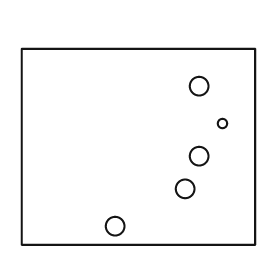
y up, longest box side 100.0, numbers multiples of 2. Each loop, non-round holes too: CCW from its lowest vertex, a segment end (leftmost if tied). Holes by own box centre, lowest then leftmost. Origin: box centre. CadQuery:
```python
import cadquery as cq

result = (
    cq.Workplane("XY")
    .moveTo(-50.0, -42.0)
    .lineTo(50.0, -42.0)
    .lineTo(50.0, 42.0)
    .lineTo(-50.0, 42.0)
    .close()
    .moveTo(-10.0, -34.0)
    .circle(4.0)
    .moveTo(20.0, -18.0)
    .circle(4.0)
    .moveTo(26.0, -4.0)
    .circle(4.0)
    .moveTo(36.0, 10.0)
    .circle(2.0)
    .moveTo(26.0, 26.0)
    .circle(4.0)
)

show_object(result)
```